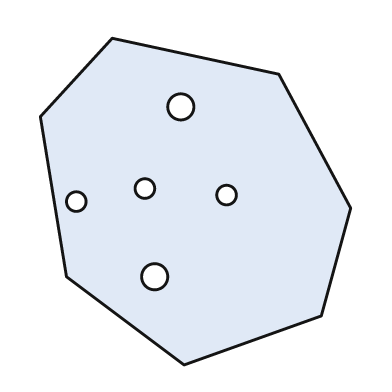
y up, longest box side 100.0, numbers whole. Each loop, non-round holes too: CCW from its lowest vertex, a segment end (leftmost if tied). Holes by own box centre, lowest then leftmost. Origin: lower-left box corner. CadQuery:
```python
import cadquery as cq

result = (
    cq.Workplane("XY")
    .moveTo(44.0, 0.0)
    .lineTo(86.0, 15.0)
    .lineTo(95.0, 48.0)
    .lineTo(73.0, 89.0)
    .lineTo(22.0, 100.0)
    .lineTo(0.0, 76.0)
    .lineTo(8.0, 27.0)
    .close()
    .moveTo(35.0, 27.0)
    .circle(4.0)
    .moveTo(11.0, 50.0)
    .circle(3.0)
    .moveTo(57.0, 52.0)
    .circle(3.0)
    .moveTo(32.0, 54.0)
    .circle(3.0)
    .moveTo(43.0, 79.0)
    .circle(4.0)
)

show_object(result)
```